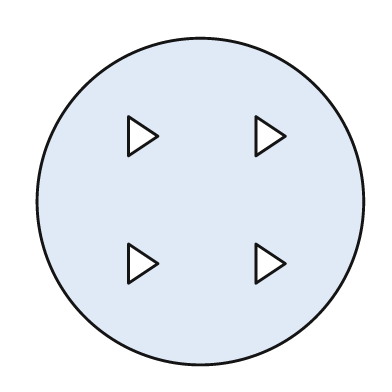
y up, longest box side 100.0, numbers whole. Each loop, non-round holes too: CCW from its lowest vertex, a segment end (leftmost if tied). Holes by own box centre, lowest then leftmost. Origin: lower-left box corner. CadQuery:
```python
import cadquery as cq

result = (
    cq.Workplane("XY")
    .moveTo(50.0, 50.0)
    .circle(50.0)
    .moveTo(28.0, 25.0)
    .lineTo(37.0, 31.0)
    .lineTo(28.0, 37.0)
    .close()
    .moveTo(67.0, 25.0)
    .lineTo(76.0, 31.0)
    .lineTo(67.0, 37.0)
    .close()
    .moveTo(28.0, 64.0)
    .lineTo(37.0, 70.0)
    .lineTo(28.0, 76.0)
    .close()
    .moveTo(67.0, 64.0)
    .lineTo(76.0, 70.0)
    .lineTo(67.0, 76.0)
    .close()
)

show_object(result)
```